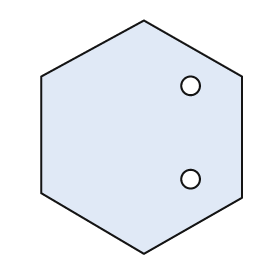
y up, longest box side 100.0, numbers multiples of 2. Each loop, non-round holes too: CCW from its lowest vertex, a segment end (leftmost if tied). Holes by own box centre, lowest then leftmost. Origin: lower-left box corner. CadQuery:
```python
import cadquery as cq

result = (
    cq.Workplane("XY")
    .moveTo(44.0, 0.0)
    .lineTo(86.0, 24.0)
    .lineTo(86.0, 76.0)
    .lineTo(44.0, 100.0)
    .lineTo(0.0, 76.0)
    .lineTo(0.0, 26.0)
    .close()
    .moveTo(64.0, 32.0)
    .circle(4.0)
    .moveTo(64.0, 72.0)
    .circle(4.0)
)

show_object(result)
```